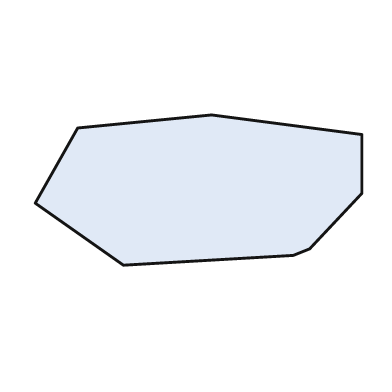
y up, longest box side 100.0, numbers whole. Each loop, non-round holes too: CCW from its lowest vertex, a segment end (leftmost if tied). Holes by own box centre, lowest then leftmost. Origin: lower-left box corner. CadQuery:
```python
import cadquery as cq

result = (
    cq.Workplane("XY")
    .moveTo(27.0, 0.0)
    .lineTo(79.0, 3.0)
    .lineTo(84.0, 5.0)
    .lineTo(100.0, 22.0)
    .lineTo(100.0, 40.0)
    .lineTo(54.0, 46.0)
    .lineTo(13.0, 42.0)
    .lineTo(0.0, 19.0)
    .close()
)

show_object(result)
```